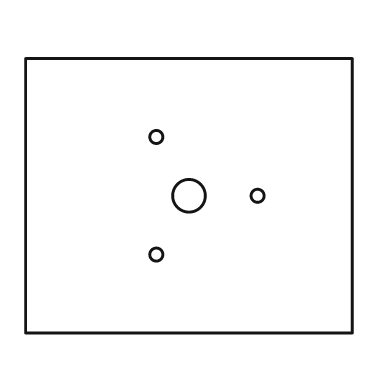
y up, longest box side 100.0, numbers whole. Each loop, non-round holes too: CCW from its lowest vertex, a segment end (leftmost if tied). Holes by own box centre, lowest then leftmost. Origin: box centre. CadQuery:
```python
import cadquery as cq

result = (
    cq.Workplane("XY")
    .moveTo(-50.0, -42.0)
    .lineTo(50.0, -42.0)
    .lineTo(50.0, 42.0)
    .lineTo(-50.0, 42.0)
    .close()
    .moveTo(-10.0, -18.0)
    .circle(2.0)
    .moveTo(0.0, 0.0)
    .circle(5.0)
    .moveTo(21.0, 0.0)
    .circle(2.0)
    .moveTo(-10.0, 18.0)
    .circle(2.0)
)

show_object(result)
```